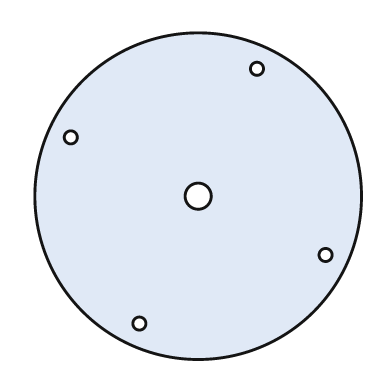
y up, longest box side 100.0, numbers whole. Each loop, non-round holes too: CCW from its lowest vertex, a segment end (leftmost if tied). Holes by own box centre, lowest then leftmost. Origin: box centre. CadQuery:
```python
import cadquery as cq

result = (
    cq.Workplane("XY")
    .moveTo(0.0, 0.0)
    .circle(50.0)
    .moveTo(-18.0, -39.0)
    .circle(2.0)
    .moveTo(39.0, -18.0)
    .circle(2.0)
    .moveTo(0.0, 0.0)
    .circle(4.0)
    .moveTo(-39.0, 18.0)
    .circle(2.0)
    .moveTo(18.0, 39.0)
    .circle(2.0)
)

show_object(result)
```